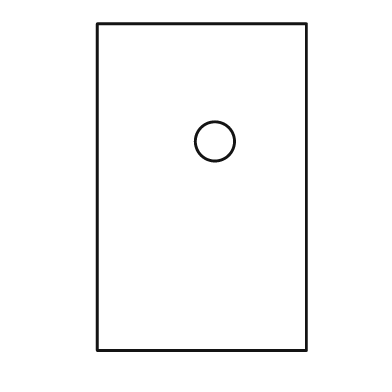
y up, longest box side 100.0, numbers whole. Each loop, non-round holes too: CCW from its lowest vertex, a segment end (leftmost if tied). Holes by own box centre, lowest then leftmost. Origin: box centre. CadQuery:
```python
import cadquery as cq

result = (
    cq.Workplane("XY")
    .moveTo(-32.0, -50.0)
    .lineTo(32.0, -50.0)
    .lineTo(32.0, 50.0)
    .lineTo(-32.0, 50.0)
    .close()
    .moveTo(4.0, 14.0)
    .circle(6.0)
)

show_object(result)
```